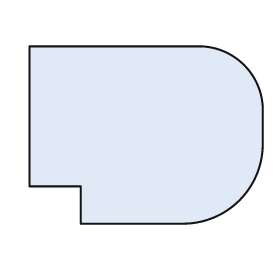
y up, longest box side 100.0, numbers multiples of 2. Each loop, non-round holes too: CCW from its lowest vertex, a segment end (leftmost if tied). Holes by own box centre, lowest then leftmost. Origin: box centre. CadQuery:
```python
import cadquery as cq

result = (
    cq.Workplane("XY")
    .moveTo(-28.0, -38.0)
    .lineTo(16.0, -38.0)
    .threePointArc((40.0, -28.0), (50.0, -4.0))
    .lineTo(50.0, 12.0)
    .threePointArc((42.0, 30.0), (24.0, 38.0))
    .lineTo(-50.0, 38.0)
    .lineTo(-50.0, -22.0)
    .lineTo(-28.0, -22.0)
    .close()
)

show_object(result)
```